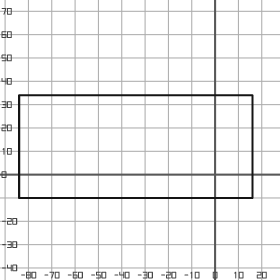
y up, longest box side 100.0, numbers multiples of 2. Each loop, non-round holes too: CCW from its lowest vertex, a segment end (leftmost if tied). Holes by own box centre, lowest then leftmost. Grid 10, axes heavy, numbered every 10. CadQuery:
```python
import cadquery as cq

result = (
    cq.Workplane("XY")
    .moveTo(-84.0, -10.0)
    .lineTo(16.0, -10.0)
    .lineTo(16.0, 34.0)
    .lineTo(-84.0, 34.0)
    .close()
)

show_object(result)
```